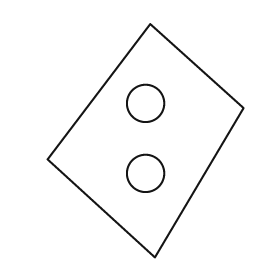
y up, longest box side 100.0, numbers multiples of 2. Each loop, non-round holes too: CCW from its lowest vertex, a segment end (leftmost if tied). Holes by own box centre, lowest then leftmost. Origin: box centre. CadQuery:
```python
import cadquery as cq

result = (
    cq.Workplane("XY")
    .moveTo(4.0, -50.0)
    .lineTo(42.0, 14.0)
    .lineTo(2.0, 50.0)
    .lineTo(-42.0, -8.0)
    .close()
    .moveTo(0.0, -14.0)
    .circle(8.0)
    .moveTo(0.0, 16.0)
    .circle(8.0)
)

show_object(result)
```